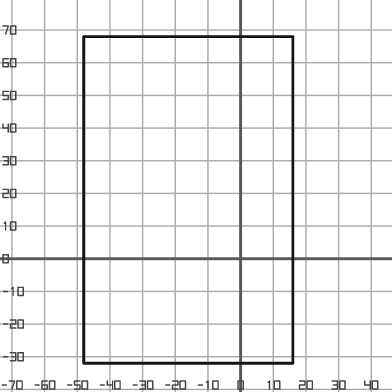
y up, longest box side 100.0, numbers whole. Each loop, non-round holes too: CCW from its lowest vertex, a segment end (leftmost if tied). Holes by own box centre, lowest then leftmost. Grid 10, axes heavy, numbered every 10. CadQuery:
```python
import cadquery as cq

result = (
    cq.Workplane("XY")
    .moveTo(-48.0, -32.0)
    .lineTo(16.0, -32.0)
    .lineTo(16.0, 68.0)
    .lineTo(-48.0, 68.0)
    .close()
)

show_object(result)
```